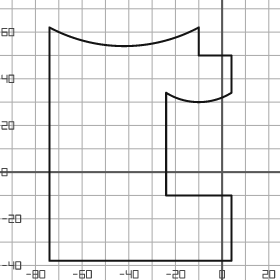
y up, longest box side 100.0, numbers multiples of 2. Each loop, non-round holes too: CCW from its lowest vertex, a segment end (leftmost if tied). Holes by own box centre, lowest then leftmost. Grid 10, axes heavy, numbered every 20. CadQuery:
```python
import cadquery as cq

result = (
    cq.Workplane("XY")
    .moveTo(-74.0, -38.0)
    .lineTo(4.0, -38.0)
    .lineTo(4.0, -10.0)
    .lineTo(-24.0, -10.0)
    .lineTo(-24.0, 34.0)
    .threePointArc((-10.0, 30.0), (4.0, 34.0))
    .lineTo(4.0, 50.0)
    .lineTo(-10.0, 50.0)
    .lineTo(-10.0, 62.0)
    .threePointArc((-42.0, 54.0), (-74.0, 62.0))
    .close()
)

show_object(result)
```